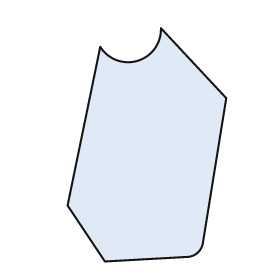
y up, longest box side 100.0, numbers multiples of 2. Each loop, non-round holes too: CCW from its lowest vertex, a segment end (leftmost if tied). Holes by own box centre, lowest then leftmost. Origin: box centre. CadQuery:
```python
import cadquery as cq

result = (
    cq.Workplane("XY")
    .moveTo(-18.0, -50.0)
    .lineTo(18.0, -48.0)
    .threePointArc((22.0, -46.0), (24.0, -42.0))
    .lineTo(34.0, 20.0)
    .lineTo(6.0, 50.0)
    .threePointArc((-4.0, 36.0), (-20.0, 42.0))
    .lineTo(-34.0, -26.0)
    .close()
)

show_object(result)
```